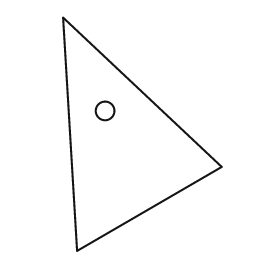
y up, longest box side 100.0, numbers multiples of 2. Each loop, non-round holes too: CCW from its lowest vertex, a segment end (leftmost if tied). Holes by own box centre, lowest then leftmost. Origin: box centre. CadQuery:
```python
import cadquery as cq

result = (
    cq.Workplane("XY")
    .moveTo(-28.0, -50.0)
    .lineTo(34.0, -14.0)
    .lineTo(-34.0, 50.0)
    .close()
    .moveTo(-16.0, 10.0)
    .circle(4.0)
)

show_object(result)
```